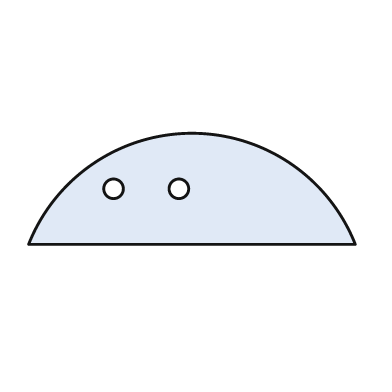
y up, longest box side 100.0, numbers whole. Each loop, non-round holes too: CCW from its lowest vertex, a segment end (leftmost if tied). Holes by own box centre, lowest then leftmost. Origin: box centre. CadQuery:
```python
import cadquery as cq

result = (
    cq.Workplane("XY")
    .moveTo(-50.0, -17.0)
    .lineTo(50.0, -17.0)
    .threePointArc((0.0, 17.0), (-50.0, -17.0))
    .close()
    .moveTo(-24.0, 0.0)
    .circle(3.0)
    .moveTo(-4.0, 0.0)
    .circle(3.0)
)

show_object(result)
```